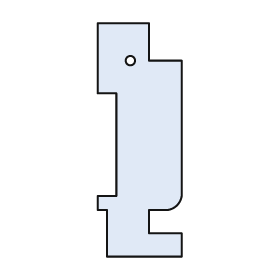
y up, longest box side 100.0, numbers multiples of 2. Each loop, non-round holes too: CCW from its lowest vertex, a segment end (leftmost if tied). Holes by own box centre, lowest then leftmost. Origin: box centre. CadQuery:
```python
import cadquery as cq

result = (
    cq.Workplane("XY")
    .moveTo(-14.0, -50.0)
    .lineTo(18.0, -50.0)
    .lineTo(18.0, -40.0)
    .lineTo(4.0, -40.0)
    .lineTo(4.0, -30.0)
    .lineTo(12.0, -30.0)
    .threePointArc((16.0, -28.0), (18.0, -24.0))
    .lineTo(18.0, 34.0)
    .lineTo(4.0, 34.0)
    .lineTo(4.0, 50.0)
    .lineTo(-18.0, 50.0)
    .lineTo(-18.0, 20.0)
    .lineTo(-10.0, 20.0)
    .lineTo(-10.0, -24.0)
    .lineTo(-18.0, -24.0)
    .lineTo(-18.0, -30.0)
    .lineTo(-14.0, -30.0)
    .close()
    .moveTo(-4.0, 34.0)
    .circle(2.0)
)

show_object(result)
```